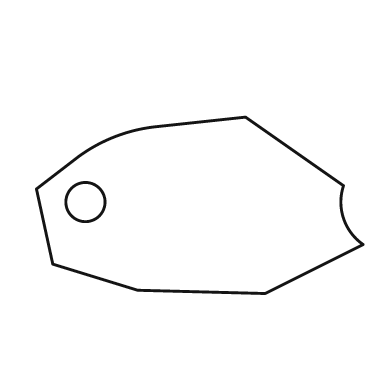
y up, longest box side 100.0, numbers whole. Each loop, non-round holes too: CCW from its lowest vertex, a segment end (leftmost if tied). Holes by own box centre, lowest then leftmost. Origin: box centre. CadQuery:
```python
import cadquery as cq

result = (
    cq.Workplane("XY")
    .moveTo(20.0, -27.0)
    .lineTo(50.0, -12.0)
    .threePointArc((44.0, -4.0), (44.0, 6.0))
    .lineTo(14.0, 27.0)
    .lineTo(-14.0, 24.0)
    .threePointArc((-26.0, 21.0), (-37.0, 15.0))
    .lineTo(-50.0, 5.0)
    .lineTo(-45.0, -18.0)
    .lineTo(-19.0, -26.0)
    .close()
    .moveTo(-35.0, 1.0)
    .circle(6.0)
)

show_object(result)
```